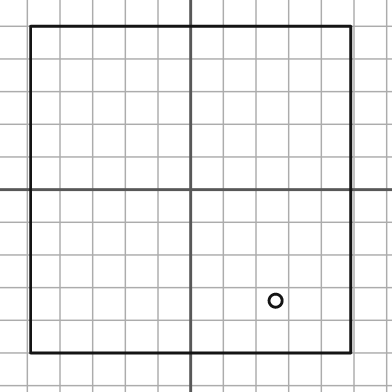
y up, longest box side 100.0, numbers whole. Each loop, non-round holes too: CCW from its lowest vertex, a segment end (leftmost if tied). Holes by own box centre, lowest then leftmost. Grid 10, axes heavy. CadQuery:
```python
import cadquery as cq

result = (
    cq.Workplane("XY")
    .moveTo(-49.0, -50.0)
    .lineTo(49.0, -50.0)
    .lineTo(49.0, 50.0)
    .lineTo(-49.0, 50.0)
    .close()
    .moveTo(26.0, -34.0)
    .circle(2.0)
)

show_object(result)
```